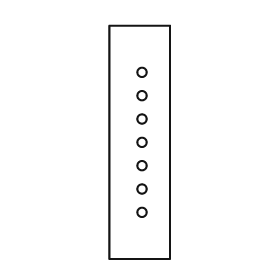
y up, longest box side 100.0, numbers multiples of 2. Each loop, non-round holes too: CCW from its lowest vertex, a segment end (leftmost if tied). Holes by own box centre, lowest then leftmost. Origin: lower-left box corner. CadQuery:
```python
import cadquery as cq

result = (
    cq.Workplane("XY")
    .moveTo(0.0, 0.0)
    .lineTo(26.0, 0.0)
    .lineTo(26.0, 100.0)
    .lineTo(0.0, 100.0)
    .close()
    .moveTo(14.0, 20.0)
    .circle(2.0)
    .moveTo(14.0, 30.0)
    .circle(2.0)
    .moveTo(14.0, 40.0)
    .circle(2.0)
    .moveTo(14.0, 50.0)
    .circle(2.0)
    .moveTo(14.0, 60.0)
    .circle(2.0)
    .moveTo(14.0, 70.0)
    .circle(2.0)
    .moveTo(14.0, 80.0)
    .circle(2.0)
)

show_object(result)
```